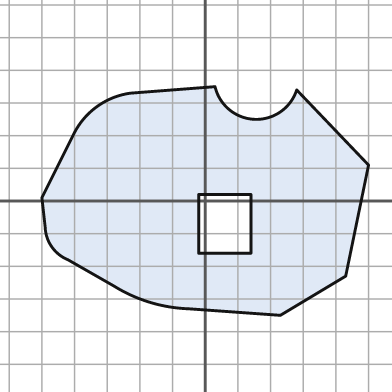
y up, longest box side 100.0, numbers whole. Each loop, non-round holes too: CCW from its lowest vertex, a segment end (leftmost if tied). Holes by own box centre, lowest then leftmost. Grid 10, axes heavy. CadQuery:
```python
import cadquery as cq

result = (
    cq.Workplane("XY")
    .moveTo(23.0, -35.0)
    .lineTo(43.0, -23.0)
    .lineTo(50.0, 11.0)
    .lineTo(28.0, 34.0)
    .threePointArc((15.0, 25.0), (3.0, 35.0))
    .lineTo(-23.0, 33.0)
    .threePointArc((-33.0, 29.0), (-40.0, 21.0))
    .lineTo(-50.0, 1.0)
    .lineTo(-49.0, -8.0)
    .threePointArc((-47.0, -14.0), (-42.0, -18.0))
    .lineTo(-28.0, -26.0)
    .threePointArc((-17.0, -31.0), (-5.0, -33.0))
    .close()
    .moveTo(-2.0, -16.0)
    .lineTo(14.0, -16.0)
    .lineTo(14.0, 2.0)
    .lineTo(-2.0, 2.0)
    .close()
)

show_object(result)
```